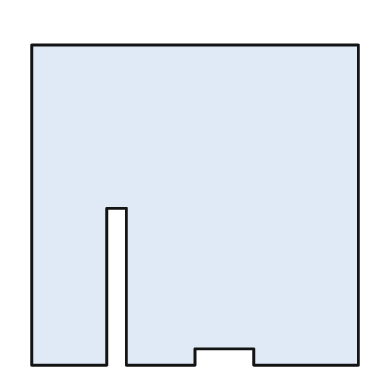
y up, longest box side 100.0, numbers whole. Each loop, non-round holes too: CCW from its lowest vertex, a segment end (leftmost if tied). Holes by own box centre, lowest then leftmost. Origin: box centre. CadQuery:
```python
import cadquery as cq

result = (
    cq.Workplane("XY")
    .moveTo(-50.0, -49.0)
    .lineTo(-27.0, -49.0)
    .lineTo(-27.0, -1.0)
    .lineTo(-21.0, -1.0)
    .lineTo(-21.0, -49.0)
    .lineTo(0.0, -49.0)
    .lineTo(0.0, -44.0)
    .lineTo(18.0, -44.0)
    .lineTo(18.0, -49.0)
    .lineTo(50.0, -49.0)
    .lineTo(50.0, 49.0)
    .lineTo(-50.0, 49.0)
    .close()
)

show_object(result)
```